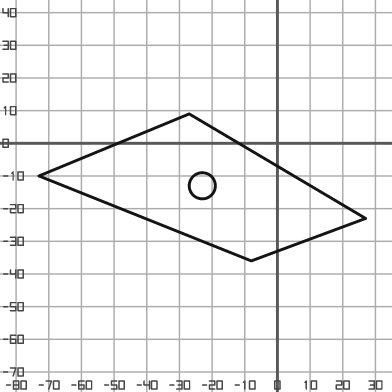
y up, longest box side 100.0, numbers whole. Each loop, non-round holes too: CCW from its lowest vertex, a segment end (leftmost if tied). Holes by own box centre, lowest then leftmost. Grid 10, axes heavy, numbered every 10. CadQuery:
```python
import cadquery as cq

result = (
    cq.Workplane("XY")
    .moveTo(-8.0, -36.0)
    .lineTo(27.0, -23.0)
    .lineTo(-27.0, 9.0)
    .lineTo(-73.0, -10.0)
    .close()
    .moveTo(-23.0, -13.0)
    .circle(4.0)
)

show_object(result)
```